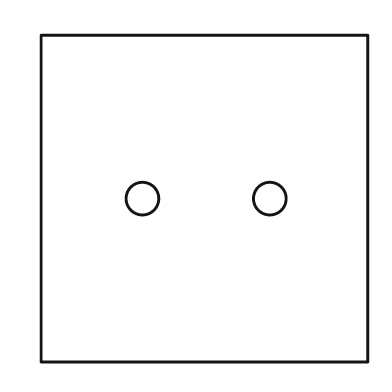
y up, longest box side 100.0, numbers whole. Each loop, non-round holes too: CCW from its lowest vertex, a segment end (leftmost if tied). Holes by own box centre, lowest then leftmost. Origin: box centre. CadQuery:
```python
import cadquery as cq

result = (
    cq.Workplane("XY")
    .moveTo(-50.0, -50.0)
    .lineTo(50.0, -50.0)
    .lineTo(50.0, 50.0)
    .lineTo(-50.0, 50.0)
    .close()
    .moveTo(-19.0, 0.0)
    .circle(5.0)
    .moveTo(20.0, 0.0)
    .circle(5.0)
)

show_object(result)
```